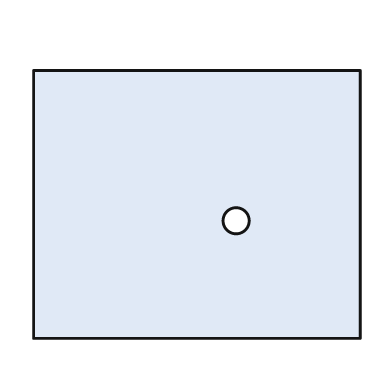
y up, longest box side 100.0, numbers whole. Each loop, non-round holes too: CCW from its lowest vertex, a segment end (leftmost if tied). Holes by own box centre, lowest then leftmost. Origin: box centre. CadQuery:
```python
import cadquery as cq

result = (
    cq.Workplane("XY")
    .moveTo(-50.0, -41.0)
    .lineTo(50.0, -41.0)
    .lineTo(50.0, 41.0)
    .lineTo(-50.0, 41.0)
    .close()
    .moveTo(12.0, -5.0)
    .circle(4.0)
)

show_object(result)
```